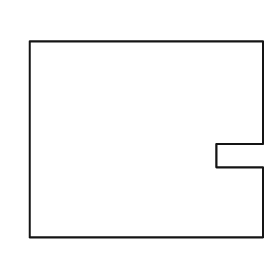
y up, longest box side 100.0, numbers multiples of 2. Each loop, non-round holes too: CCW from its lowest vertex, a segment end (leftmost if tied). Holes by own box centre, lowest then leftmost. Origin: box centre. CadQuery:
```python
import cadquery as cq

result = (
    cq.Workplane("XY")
    .moveTo(-50.0, -42.0)
    .lineTo(50.0, -42.0)
    .lineTo(50.0, -12.0)
    .lineTo(30.0, -12.0)
    .lineTo(30.0, -2.0)
    .lineTo(50.0, -2.0)
    .lineTo(50.0, 42.0)
    .lineTo(-50.0, 42.0)
    .close()
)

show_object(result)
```